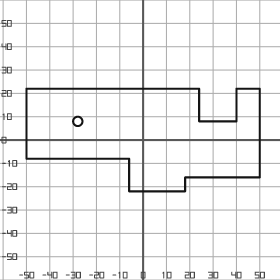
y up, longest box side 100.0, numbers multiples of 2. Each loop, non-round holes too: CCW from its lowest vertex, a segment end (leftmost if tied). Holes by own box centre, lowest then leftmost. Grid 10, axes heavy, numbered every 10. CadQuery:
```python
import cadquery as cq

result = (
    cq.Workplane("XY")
    .moveTo(-6.0, -22.0)
    .lineTo(18.0, -22.0)
    .lineTo(18.0, -16.0)
    .lineTo(50.0, -16.0)
    .lineTo(50.0, 22.0)
    .lineTo(40.0, 22.0)
    .lineTo(40.0, 8.0)
    .lineTo(24.0, 8.0)
    .lineTo(24.0, 22.0)
    .lineTo(-50.0, 22.0)
    .lineTo(-50.0, -8.0)
    .lineTo(-6.0, -8.0)
    .close()
    .moveTo(-28.0, 8.0)
    .circle(2.0)
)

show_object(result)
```